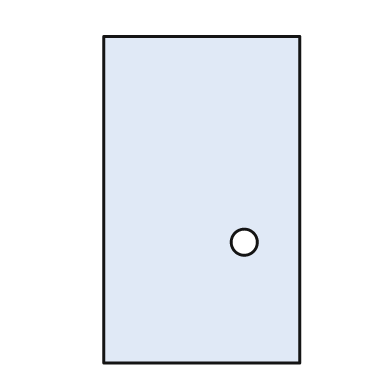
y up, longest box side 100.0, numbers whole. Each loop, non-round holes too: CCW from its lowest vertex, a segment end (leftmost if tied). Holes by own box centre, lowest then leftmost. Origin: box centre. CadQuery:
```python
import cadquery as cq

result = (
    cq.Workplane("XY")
    .moveTo(-30.0, -50.0)
    .lineTo(30.0, -50.0)
    .lineTo(30.0, 50.0)
    .lineTo(-30.0, 50.0)
    .close()
    .moveTo(13.0, -13.0)
    .circle(4.0)
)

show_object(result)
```